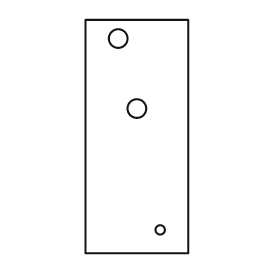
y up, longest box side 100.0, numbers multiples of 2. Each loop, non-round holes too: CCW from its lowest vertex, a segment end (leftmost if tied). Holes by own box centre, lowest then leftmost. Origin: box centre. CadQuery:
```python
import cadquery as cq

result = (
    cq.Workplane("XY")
    .moveTo(-22.0, -50.0)
    .lineTo(22.0, -50.0)
    .lineTo(22.0, 50.0)
    .lineTo(-22.0, 50.0)
    .close()
    .moveTo(10.0, -40.0)
    .circle(2.0)
    .moveTo(0.0, 12.0)
    .circle(4.0)
    .moveTo(-8.0, 42.0)
    .circle(4.0)
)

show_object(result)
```